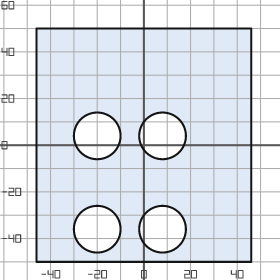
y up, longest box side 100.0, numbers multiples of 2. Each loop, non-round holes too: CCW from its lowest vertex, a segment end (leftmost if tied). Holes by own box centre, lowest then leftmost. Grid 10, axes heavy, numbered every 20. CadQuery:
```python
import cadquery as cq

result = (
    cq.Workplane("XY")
    .moveTo(-46.0, -50.0)
    .lineTo(46.0, -50.0)
    .lineTo(46.0, 50.0)
    .lineTo(-46.0, 50.0)
    .close()
    .moveTo(-20.0, -36.0)
    .circle(10.0)
    .moveTo(8.0, -36.0)
    .circle(10.0)
    .moveTo(-20.0, 4.0)
    .circle(10.0)
    .moveTo(8.0, 4.0)
    .circle(10.0)
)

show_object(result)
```